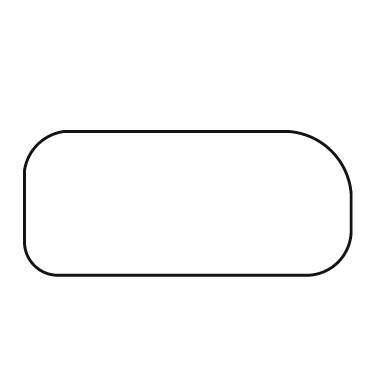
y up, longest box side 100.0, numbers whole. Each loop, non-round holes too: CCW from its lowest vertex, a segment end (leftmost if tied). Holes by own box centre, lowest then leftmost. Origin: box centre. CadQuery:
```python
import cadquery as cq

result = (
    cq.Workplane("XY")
    .moveTo(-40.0, -22.0)
    .lineTo(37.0, -22.0)
    .threePointArc((46.0, -18.0), (50.0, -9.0))
    .lineTo(50.0, 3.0)
    .threePointArc((44.0, 16.0), (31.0, 22.0))
    .lineTo(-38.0, 22.0)
    .threePointArc((-46.0, 18.0), (-50.0, 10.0))
    .lineTo(-50.0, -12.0)
    .threePointArc((-47.0, -19.0), (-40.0, -22.0))
    .close()
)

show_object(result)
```